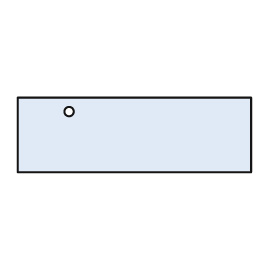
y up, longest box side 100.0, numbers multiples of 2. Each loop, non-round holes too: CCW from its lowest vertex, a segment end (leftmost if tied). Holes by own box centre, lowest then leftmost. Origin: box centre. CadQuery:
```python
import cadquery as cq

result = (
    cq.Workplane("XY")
    .moveTo(-50.0, -16.0)
    .lineTo(50.0, -16.0)
    .lineTo(50.0, 16.0)
    .lineTo(-50.0, 16.0)
    .close()
    .moveTo(-28.0, 10.0)
    .circle(2.0)
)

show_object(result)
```